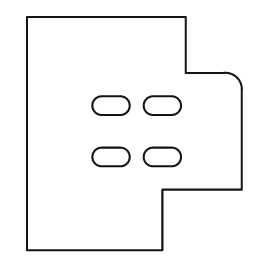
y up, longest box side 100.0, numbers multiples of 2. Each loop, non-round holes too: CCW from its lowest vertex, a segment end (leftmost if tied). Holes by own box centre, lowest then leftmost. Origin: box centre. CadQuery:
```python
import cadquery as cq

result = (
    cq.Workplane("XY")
    .moveTo(-46.0, -50.0)
    .lineTo(12.0, -50.0)
    .lineTo(12.0, -24.0)
    .lineTo(46.0, -24.0)
    .lineTo(46.0, 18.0)
    .threePointArc((44.0, 24.0), (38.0, 26.0))
    .lineTo(22.0, 26.0)
    .lineTo(22.0, 50.0)
    .lineTo(-46.0, 50.0)
    .close()
    .moveTo(-14.0, -14.0)
    .lineTo(-6.0, -14.0)
    .threePointArc((-2.0, -10.0), (-6.0, -6.0))
    .lineTo(-14.0, -6.0)
    .threePointArc((-18.0, -10.0), (-14.0, -14.0))
    .close()
    .moveTo(8.0, -14.0)
    .lineTo(16.0, -14.0)
    .threePointArc((20.0, -10.0), (16.0, -6.0))
    .lineTo(8.0, -6.0)
    .threePointArc((4.0, -10.0), (8.0, -14.0))
    .close()
    .moveTo(-14.0, 8.0)
    .lineTo(-6.0, 8.0)
    .threePointArc((-2.0, 12.0), (-6.0, 16.0))
    .lineTo(-14.0, 16.0)
    .threePointArc((-18.0, 12.0), (-14.0, 8.0))
    .close()
    .moveTo(8.0, 8.0)
    .lineTo(16.0, 8.0)
    .threePointArc((20.0, 12.0), (16.0, 16.0))
    .lineTo(8.0, 16.0)
    .threePointArc((4.0, 12.0), (8.0, 8.0))
    .close()
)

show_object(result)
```